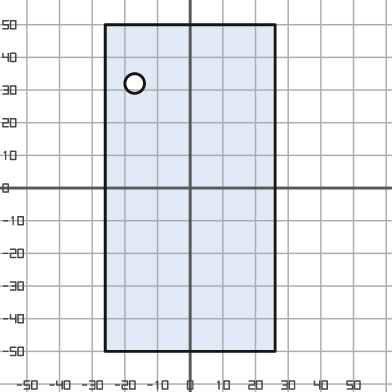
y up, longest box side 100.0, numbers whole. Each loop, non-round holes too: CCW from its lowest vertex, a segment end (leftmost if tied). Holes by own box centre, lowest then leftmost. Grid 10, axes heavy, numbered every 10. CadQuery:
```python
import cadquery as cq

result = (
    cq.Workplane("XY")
    .moveTo(-26.0, -50.0)
    .lineTo(26.0, -50.0)
    .lineTo(26.0, 50.0)
    .lineTo(-26.0, 50.0)
    .close()
    .moveTo(-17.0, 32.0)
    .circle(3.0)
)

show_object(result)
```